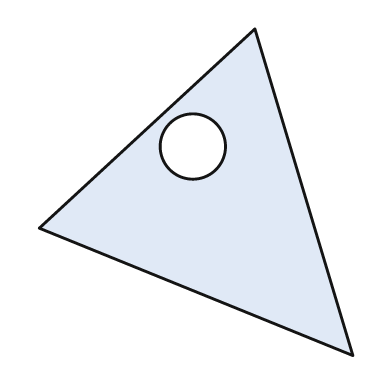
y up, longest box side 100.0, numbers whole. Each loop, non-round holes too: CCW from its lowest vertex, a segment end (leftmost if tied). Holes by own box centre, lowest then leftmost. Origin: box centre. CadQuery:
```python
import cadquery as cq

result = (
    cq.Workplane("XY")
    .moveTo(48.0, -50.0)
    .lineTo(18.0, 50.0)
    .lineTo(-48.0, -11.0)
    .close()
    .moveTo(-1.0, 14.0)
    .circle(10.0)
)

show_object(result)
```